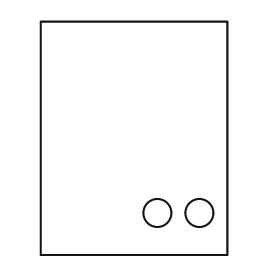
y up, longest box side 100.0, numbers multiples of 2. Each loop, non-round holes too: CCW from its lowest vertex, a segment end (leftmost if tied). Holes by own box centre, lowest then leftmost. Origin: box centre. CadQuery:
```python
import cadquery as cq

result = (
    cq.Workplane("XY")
    .moveTo(-40.0, -50.0)
    .lineTo(40.0, -50.0)
    .lineTo(40.0, 50.0)
    .lineTo(-40.0, 50.0)
    .close()
    .moveTo(10.0, -32.0)
    .circle(6.0)
    .moveTo(28.0, -32.0)
    .circle(6.0)
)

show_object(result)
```